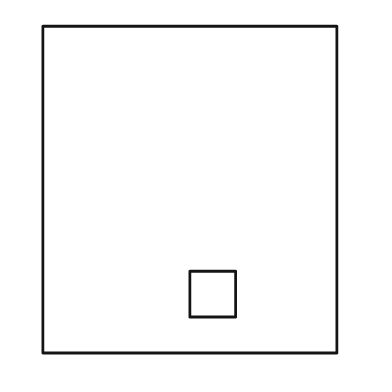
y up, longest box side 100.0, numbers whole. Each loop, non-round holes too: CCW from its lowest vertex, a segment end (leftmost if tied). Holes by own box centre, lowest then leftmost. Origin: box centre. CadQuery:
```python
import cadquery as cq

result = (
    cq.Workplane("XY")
    .moveTo(-45.0, -50.0)
    .lineTo(45.0, -50.0)
    .lineTo(45.0, 50.0)
    .lineTo(-45.0, 50.0)
    .close()
    .moveTo(0.0, -39.0)
    .lineTo(14.0, -39.0)
    .lineTo(14.0, -25.0)
    .lineTo(0.0, -25.0)
    .close()
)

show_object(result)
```